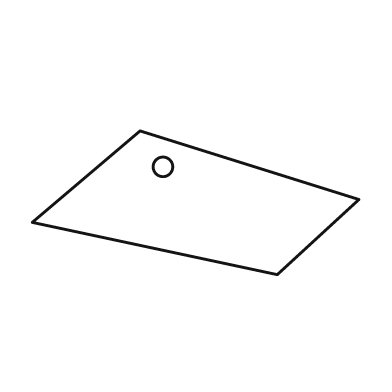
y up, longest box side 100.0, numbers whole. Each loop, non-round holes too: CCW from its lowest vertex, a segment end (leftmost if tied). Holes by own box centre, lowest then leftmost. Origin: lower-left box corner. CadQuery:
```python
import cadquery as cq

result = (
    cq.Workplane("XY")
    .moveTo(75.0, 0.0)
    .lineTo(100.0, 23.0)
    .lineTo(33.0, 44.0)
    .lineTo(0.0, 16.0)
    .close()
    .moveTo(40.0, 33.0)
    .circle(3.0)
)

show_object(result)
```